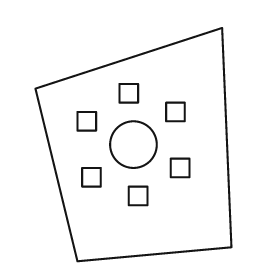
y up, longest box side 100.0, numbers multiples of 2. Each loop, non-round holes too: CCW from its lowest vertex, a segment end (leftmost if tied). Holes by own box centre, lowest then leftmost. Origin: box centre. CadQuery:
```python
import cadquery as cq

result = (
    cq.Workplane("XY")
    .moveTo(-24.0, -50.0)
    .lineTo(42.0, -44.0)
    .lineTo(38.0, 50.0)
    .lineTo(-42.0, 24.0)
    .close()
    .moveTo(-2.0, -26.0)
    .lineTo(6.0, -26.0)
    .lineTo(6.0, -18.0)
    .lineTo(-2.0, -18.0)
    .close()
    .moveTo(-22.0, -18.0)
    .lineTo(-14.0, -18.0)
    .lineTo(-14.0, -10.0)
    .lineTo(-22.0, -10.0)
    .close()
    .moveTo(16.0, -14.0)
    .lineTo(24.0, -14.0)
    .lineTo(24.0, -6.0)
    .lineTo(16.0, -6.0)
    .close()
    .moveTo(0.0, 0.0)
    .circle(10.0)
    .moveTo(-24.0, 6.0)
    .lineTo(-16.0, 6.0)
    .lineTo(-16.0, 14.0)
    .lineTo(-24.0, 14.0)
    .close()
    .moveTo(14.0, 10.0)
    .lineTo(22.0, 10.0)
    .lineTo(22.0, 18.0)
    .lineTo(14.0, 18.0)
    .close()
    .moveTo(-6.0, 18.0)
    .lineTo(2.0, 18.0)
    .lineTo(2.0, 26.0)
    .lineTo(-6.0, 26.0)
    .close()
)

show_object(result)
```